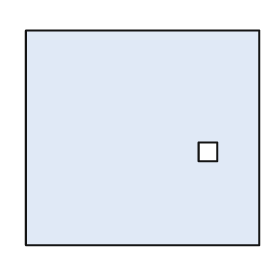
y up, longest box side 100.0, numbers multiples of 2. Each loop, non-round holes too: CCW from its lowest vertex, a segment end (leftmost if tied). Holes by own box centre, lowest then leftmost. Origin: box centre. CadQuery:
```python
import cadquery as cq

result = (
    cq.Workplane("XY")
    .moveTo(-50.0, -46.0)
    .lineTo(50.0, -46.0)
    .lineTo(50.0, 46.0)
    .lineTo(-50.0, 46.0)
    .close()
    .moveTo(24.0, -10.0)
    .lineTo(32.0, -10.0)
    .lineTo(32.0, -2.0)
    .lineTo(24.0, -2.0)
    .close()
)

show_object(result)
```